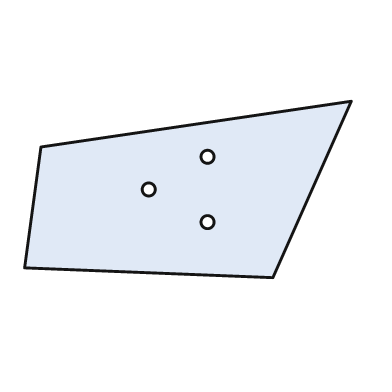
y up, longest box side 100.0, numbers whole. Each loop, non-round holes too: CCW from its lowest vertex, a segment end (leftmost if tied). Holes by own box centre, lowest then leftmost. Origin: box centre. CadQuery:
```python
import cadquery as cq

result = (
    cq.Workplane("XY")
    .moveTo(26.0, -27.0)
    .lineTo(50.0, 27.0)
    .lineTo(-45.0, 13.0)
    .lineTo(-50.0, -24.0)
    .close()
    .moveTo(6.0, -10.0)
    .circle(2.0)
    .moveTo(-12.0, 0.0)
    .circle(2.0)
    .moveTo(6.0, 10.0)
    .circle(2.0)
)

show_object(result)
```